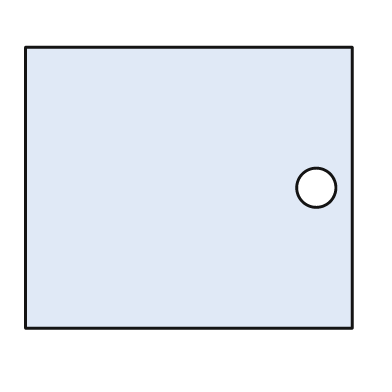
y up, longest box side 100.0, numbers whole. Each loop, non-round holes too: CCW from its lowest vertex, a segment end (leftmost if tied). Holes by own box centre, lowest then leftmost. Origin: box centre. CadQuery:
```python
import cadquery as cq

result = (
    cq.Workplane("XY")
    .moveTo(-50.0, -43.0)
    .lineTo(50.0, -43.0)
    .lineTo(50.0, 43.0)
    .lineTo(-50.0, 43.0)
    .close()
    .moveTo(39.0, 0.0)
    .circle(6.0)
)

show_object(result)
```